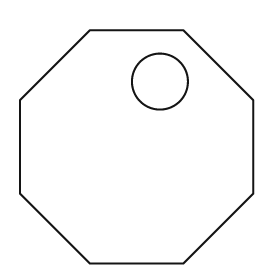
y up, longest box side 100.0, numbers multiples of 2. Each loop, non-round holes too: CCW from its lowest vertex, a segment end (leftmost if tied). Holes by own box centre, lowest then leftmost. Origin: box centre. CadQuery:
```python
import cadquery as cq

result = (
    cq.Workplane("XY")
    .moveTo(-20.0, -50.0)
    .lineTo(20.0, -50.0)
    .lineTo(50.0, -20.0)
    .lineTo(50.0, 20.0)
    .lineTo(20.0, 50.0)
    .lineTo(-20.0, 50.0)
    .lineTo(-50.0, 20.0)
    .lineTo(-50.0, -20.0)
    .close()
    .moveTo(10.0, 28.0)
    .circle(12.0)
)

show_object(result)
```